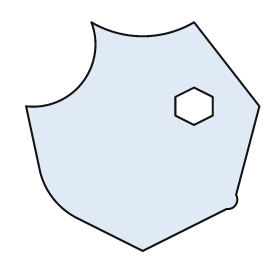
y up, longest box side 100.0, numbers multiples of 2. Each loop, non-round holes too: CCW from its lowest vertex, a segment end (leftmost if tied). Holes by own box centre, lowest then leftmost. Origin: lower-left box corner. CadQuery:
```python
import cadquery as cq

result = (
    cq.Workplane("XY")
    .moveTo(50.0, 0.0)
    .lineTo(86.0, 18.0)
    .threePointArc((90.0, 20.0), (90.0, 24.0))
    .lineTo(100.0, 62.0)
    .lineTo(72.0, 98.0)
    .threePointArc((50.0, 92.0), (28.0, 98.0))
    .threePointArc((24.0, 72.0), (0.0, 62.0))
    .lineTo(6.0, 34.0)
    .threePointArc((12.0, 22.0), (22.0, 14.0))
    .close()
    .moveTo(72.0, 54.0)
    .lineTo(80.0, 58.0)
    .lineTo(80.0, 66.0)
    .lineTo(72.0, 70.0)
    .lineTo(64.0, 66.0)
    .lineTo(64.0, 58.0)
    .close()
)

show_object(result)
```